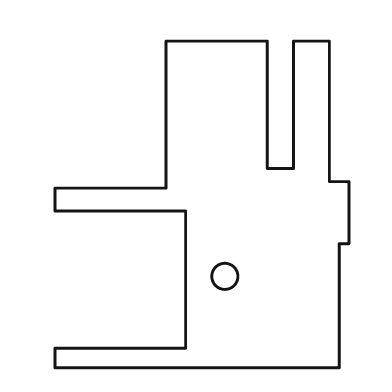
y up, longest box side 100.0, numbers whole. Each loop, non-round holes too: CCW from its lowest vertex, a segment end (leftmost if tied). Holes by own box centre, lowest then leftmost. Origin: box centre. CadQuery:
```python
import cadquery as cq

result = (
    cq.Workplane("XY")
    .moveTo(-45.0, -50.0)
    .lineTo(42.0, -50.0)
    .lineTo(42.0, -12.0)
    .lineTo(45.0, -12.0)
    .lineTo(45.0, 7.0)
    .lineTo(39.0, 7.0)
    .lineTo(39.0, 50.0)
    .lineTo(28.0, 50.0)
    .lineTo(28.0, 11.0)
    .lineTo(20.0, 11.0)
    .lineTo(20.0, 50.0)
    .lineTo(-11.0, 50.0)
    .lineTo(-11.0, 5.0)
    .lineTo(-45.0, 5.0)
    .lineTo(-45.0, -2.0)
    .lineTo(-5.0, -2.0)
    .lineTo(-5.0, -44.0)
    .lineTo(-45.0, -44.0)
    .close()
    .moveTo(7.0, -22.0)
    .circle(4.0)
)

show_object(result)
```